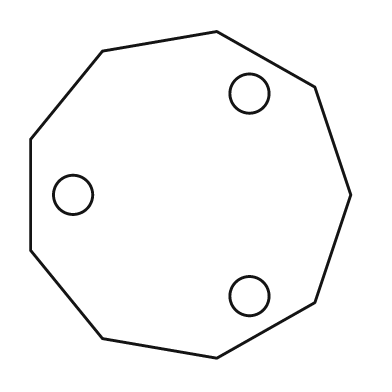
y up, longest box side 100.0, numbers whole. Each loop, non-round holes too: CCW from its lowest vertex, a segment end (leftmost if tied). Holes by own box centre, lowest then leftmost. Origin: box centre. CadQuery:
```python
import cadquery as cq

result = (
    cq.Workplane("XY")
    .moveTo(8.0, -50.0)
    .lineTo(38.0, -33.0)
    .lineTo(49.0, 0.0)
    .lineTo(38.0, 33.0)
    .lineTo(8.0, 50.0)
    .lineTo(-27.0, 44.0)
    .lineTo(-49.0, 17.0)
    .lineTo(-49.0, -17.0)
    .lineTo(-27.0, -44.0)
    .close()
    .moveTo(18.0, -31.0)
    .circle(6.0)
    .moveTo(-36.0, 0.0)
    .circle(6.0)
    .moveTo(18.0, 31.0)
    .circle(6.0)
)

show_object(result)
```